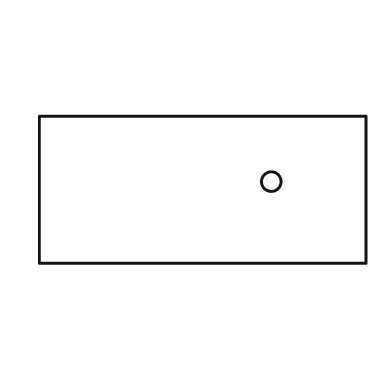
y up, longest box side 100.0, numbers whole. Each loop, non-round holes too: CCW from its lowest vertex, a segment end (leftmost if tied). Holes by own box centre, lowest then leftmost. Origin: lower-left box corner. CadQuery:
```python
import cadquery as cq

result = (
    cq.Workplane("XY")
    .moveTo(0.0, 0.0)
    .lineTo(100.0, 0.0)
    .lineTo(100.0, 45.0)
    .lineTo(0.0, 45.0)
    .close()
    .moveTo(71.0, 25.0)
    .circle(3.0)
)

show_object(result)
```